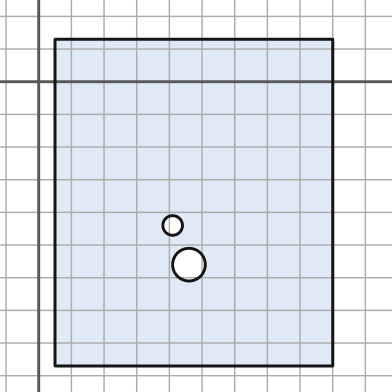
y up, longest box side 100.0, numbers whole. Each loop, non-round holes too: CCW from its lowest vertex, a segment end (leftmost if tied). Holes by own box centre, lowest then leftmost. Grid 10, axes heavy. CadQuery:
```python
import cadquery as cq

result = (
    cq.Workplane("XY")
    .moveTo(5.0, -87.0)
    .lineTo(90.0, -87.0)
    .lineTo(90.0, 13.0)
    .lineTo(5.0, 13.0)
    .close()
    .moveTo(46.0, -56.0)
    .circle(5.0)
    .moveTo(41.0, -44.0)
    .circle(3.0)
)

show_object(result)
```